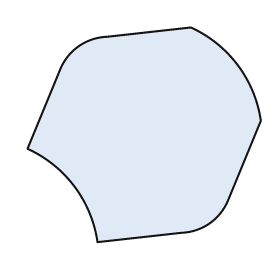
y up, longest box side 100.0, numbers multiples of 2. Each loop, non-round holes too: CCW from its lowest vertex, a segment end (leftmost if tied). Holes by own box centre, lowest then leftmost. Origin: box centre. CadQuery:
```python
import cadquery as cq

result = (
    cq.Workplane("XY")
    .moveTo(-20.0, -46.0)
    .lineTo(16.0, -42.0)
    .threePointArc((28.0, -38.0), (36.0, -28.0))
    .lineTo(50.0, 6.0)
    .threePointArc((40.0, 30.0), (20.0, 46.0))
    .lineTo(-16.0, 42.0)
    .threePointArc((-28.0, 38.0), (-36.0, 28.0))
    .lineTo(-50.0, -6.0)
    .threePointArc((-30.0, -22.0), (-20.0, -46.0))
    .close()
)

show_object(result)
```